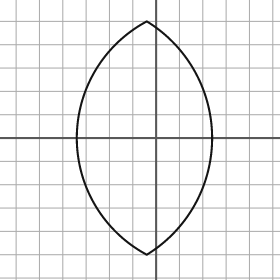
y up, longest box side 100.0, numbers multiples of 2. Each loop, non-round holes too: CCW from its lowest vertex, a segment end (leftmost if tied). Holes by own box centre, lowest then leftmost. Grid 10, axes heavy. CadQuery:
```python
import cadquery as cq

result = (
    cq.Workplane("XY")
    .moveTo(-4.0, -50.0)
    .threePointArc((24.0, 0.0), (-4.0, 50.0))
    .threePointArc((-34.0, 0.0), (-4.0, -50.0))
    .close()
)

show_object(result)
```